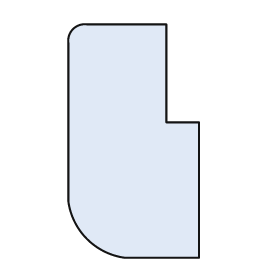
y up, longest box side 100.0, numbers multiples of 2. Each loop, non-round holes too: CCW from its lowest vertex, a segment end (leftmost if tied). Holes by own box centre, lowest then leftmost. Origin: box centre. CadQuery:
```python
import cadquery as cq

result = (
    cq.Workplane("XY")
    .moveTo(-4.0, -50.0)
    .lineTo(28.0, -50.0)
    .lineTo(28.0, 8.0)
    .lineTo(14.0, 8.0)
    .lineTo(14.0, 50.0)
    .lineTo(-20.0, 50.0)
    .threePointArc((-26.0, 48.0), (-28.0, 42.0))
    .lineTo(-28.0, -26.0)
    .threePointArc((-20.0, -42.0), (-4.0, -50.0))
    .close()
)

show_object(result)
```